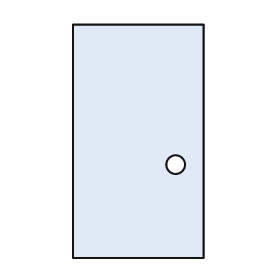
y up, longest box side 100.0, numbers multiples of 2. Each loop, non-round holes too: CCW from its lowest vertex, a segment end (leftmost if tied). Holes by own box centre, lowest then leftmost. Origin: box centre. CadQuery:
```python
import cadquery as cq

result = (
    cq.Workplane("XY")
    .moveTo(-28.0, -50.0)
    .lineTo(28.0, -50.0)
    .lineTo(28.0, 50.0)
    .lineTo(-28.0, 50.0)
    .close()
    .moveTo(16.0, -10.0)
    .circle(4.0)
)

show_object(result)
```